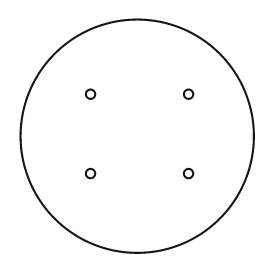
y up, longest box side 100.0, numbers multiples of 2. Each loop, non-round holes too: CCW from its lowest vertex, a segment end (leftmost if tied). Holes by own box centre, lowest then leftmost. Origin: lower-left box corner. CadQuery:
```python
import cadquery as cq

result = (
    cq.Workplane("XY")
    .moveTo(50.0, 50.0)
    .circle(50.0)
    .moveTo(30.0, 34.0)
    .circle(2.0)
    .moveTo(72.0, 34.0)
    .circle(2.0)
    .moveTo(30.0, 68.0)
    .circle(2.0)
    .moveTo(72.0, 68.0)
    .circle(2.0)
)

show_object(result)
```